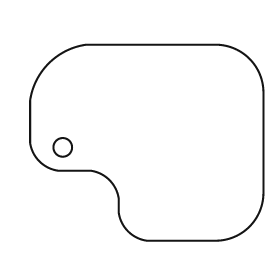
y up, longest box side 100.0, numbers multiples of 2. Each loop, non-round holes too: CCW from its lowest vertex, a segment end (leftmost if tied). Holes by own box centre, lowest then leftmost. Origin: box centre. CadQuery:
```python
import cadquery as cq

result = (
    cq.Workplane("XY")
    .moveTo(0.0, -42.0)
    .lineTo(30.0, -42.0)
    .threePointArc((44.0, -36.0), (50.0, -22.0))
    .lineTo(50.0, 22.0)
    .threePointArc((44.0, 36.0), (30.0, 42.0))
    .lineTo(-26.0, 42.0)
    .threePointArc((-42.0, 34.0), (-50.0, 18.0))
    .lineTo(-50.0, 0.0)
    .threePointArc((-46.0, -8.0), (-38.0, -12.0))
    .lineTo(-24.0, -12.0)
    .threePointArc((-16.0, -16.0), (-12.0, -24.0))
    .lineTo(-12.0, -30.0)
    .threePointArc((-8.0, -38.0), (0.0, -42.0))
    .close()
    .moveTo(-36.0, -2.0)
    .circle(4.0)
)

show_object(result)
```